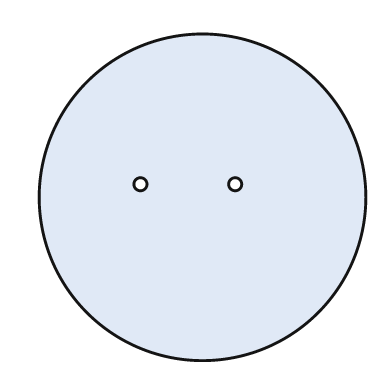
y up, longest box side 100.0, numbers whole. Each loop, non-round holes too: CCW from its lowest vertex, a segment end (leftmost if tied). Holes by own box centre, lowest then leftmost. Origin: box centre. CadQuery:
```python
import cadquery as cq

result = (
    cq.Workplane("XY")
    .moveTo(0.0, 0.0)
    .circle(50.0)
    .moveTo(-19.0, 4.0)
    .circle(2.0)
    .moveTo(10.0, 4.0)
    .circle(2.0)
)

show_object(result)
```